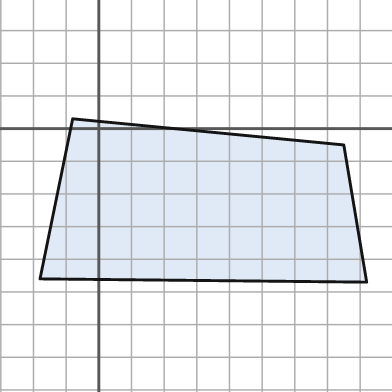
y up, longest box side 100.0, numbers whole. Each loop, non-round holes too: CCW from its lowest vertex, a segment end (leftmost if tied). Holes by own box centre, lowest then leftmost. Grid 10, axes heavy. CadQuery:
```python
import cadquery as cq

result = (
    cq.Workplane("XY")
    .moveTo(82.0, -47.0)
    .lineTo(75.0, -5.0)
    .lineTo(-8.0, 3.0)
    .lineTo(-18.0, -46.0)
    .close()
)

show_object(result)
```